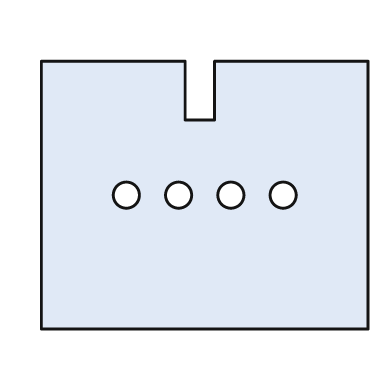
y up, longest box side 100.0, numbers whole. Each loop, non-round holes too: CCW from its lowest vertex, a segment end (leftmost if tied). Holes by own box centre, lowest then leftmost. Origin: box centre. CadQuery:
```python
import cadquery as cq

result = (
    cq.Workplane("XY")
    .moveTo(-50.0, -41.0)
    .lineTo(50.0, -41.0)
    .lineTo(50.0, 41.0)
    .lineTo(3.0, 41.0)
    .lineTo(3.0, 23.0)
    .lineTo(-6.0, 23.0)
    .lineTo(-6.0, 41.0)
    .lineTo(-50.0, 41.0)
    .close()
    .moveTo(-24.0, 0.0)
    .circle(4.0)
    .moveTo(-8.0, 0.0)
    .circle(4.0)
    .moveTo(8.0, 0.0)
    .circle(4.0)
    .moveTo(24.0, 0.0)
    .circle(4.0)
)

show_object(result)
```